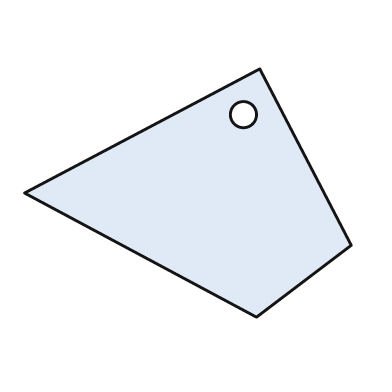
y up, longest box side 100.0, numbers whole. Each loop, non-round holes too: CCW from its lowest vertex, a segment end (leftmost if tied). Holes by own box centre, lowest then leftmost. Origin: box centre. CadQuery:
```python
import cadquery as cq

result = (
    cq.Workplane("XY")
    .moveTo(21.0, -38.0)
    .lineTo(50.0, -16.0)
    .lineTo(22.0, 38.0)
    .lineTo(-50.0, 0.0)
    .close()
    .moveTo(17.0, 24.0)
    .circle(4.0)
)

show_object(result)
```